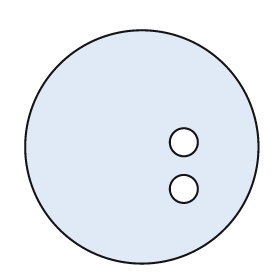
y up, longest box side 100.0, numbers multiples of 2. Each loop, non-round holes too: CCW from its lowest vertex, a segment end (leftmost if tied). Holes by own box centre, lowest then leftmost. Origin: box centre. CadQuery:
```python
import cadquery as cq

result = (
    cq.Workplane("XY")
    .moveTo(0.0, 0.0)
    .circle(50.0)
    .moveTo(18.0, -18.0)
    .circle(6.0)
    .moveTo(18.0, 2.0)
    .circle(6.0)
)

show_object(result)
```